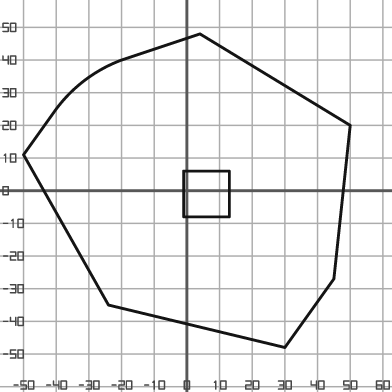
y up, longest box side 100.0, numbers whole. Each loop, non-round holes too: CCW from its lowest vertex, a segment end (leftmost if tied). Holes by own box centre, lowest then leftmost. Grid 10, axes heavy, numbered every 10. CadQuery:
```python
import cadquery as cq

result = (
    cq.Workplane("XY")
    .moveTo(30.0, -48.0)
    .lineTo(45.0, -27.0)
    .lineTo(50.0, 20.0)
    .lineTo(4.0, 48.0)
    .lineTo(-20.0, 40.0)
    .threePointArc((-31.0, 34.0), (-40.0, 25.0))
    .lineTo(-50.0, 11.0)
    .lineTo(-24.0, -35.0)
    .close()
    .moveTo(-1.0, -8.0)
    .lineTo(13.0, -8.0)
    .lineTo(13.0, 6.0)
    .lineTo(-1.0, 6.0)
    .close()
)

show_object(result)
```